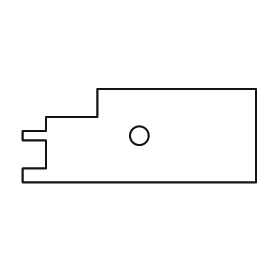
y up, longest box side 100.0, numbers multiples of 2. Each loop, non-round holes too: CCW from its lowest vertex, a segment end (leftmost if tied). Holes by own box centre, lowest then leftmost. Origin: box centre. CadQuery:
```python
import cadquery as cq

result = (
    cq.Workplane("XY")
    .moveTo(-50.0, -20.0)
    .lineTo(50.0, -20.0)
    .lineTo(50.0, 20.0)
    .lineTo(-18.0, 20.0)
    .lineTo(-18.0, 8.0)
    .lineTo(-40.0, 8.0)
    .lineTo(-40.0, 2.0)
    .lineTo(-50.0, 2.0)
    .lineTo(-50.0, -2.0)
    .lineTo(-40.0, -2.0)
    .lineTo(-40.0, -14.0)
    .lineTo(-50.0, -14.0)
    .close()
    .moveTo(0.0, 0.0)
    .circle(4.0)
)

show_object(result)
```